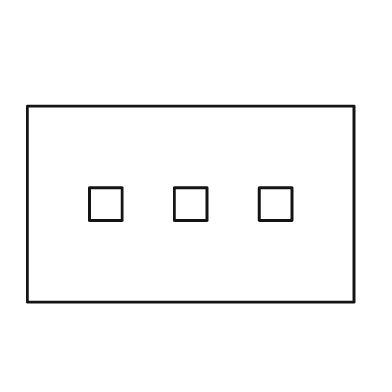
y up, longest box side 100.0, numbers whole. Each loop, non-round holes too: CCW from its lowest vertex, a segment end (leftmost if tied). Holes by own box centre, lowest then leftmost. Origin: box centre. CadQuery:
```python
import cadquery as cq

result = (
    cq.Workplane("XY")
    .moveTo(-50.0, -30.0)
    .lineTo(50.0, -30.0)
    .lineTo(50.0, 30.0)
    .lineTo(-50.0, 30.0)
    .close()
    .moveTo(-31.0, -5.0)
    .lineTo(-21.0, -5.0)
    .lineTo(-21.0, 5.0)
    .lineTo(-31.0, 5.0)
    .close()
    .moveTo(-5.0, -5.0)
    .lineTo(5.0, -5.0)
    .lineTo(5.0, 5.0)
    .lineTo(-5.0, 5.0)
    .close()
    .moveTo(21.0, -5.0)
    .lineTo(31.0, -5.0)
    .lineTo(31.0, 5.0)
    .lineTo(21.0, 5.0)
    .close()
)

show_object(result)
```